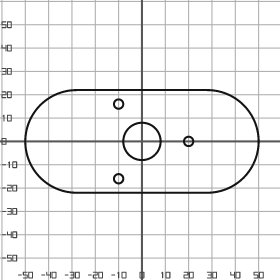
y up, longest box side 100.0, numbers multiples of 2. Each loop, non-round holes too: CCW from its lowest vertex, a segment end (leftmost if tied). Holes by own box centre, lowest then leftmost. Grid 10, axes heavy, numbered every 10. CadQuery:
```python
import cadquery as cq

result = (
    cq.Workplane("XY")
    .moveTo(-28.0, -22.0)
    .lineTo(28.0, -22.0)
    .threePointArc((50.0, 0.0), (28.0, 22.0))
    .lineTo(-28.0, 22.0)
    .threePointArc((-50.0, 0.0), (-28.0, -22.0))
    .close()
    .moveTo(-10.0, -16.0)
    .circle(2.0)
    .moveTo(0.0, 0.0)
    .circle(8.0)
    .moveTo(20.0, 0.0)
    .circle(2.0)
    .moveTo(-10.0, 16.0)
    .circle(2.0)
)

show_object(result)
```